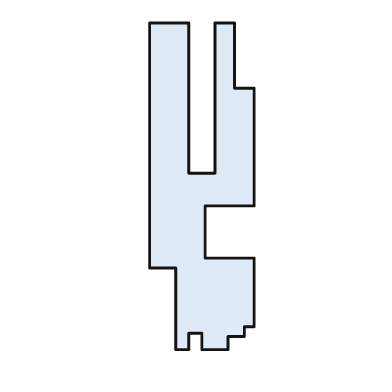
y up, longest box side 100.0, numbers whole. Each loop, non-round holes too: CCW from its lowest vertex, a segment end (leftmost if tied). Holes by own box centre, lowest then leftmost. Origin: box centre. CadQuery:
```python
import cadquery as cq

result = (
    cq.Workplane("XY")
    .moveTo(-8.0, -50.0)
    .lineTo(-4.0, -50.0)
    .lineTo(-4.0, -45.0)
    .lineTo(0.0, -45.0)
    .lineTo(0.0, -50.0)
    .lineTo(8.0, -50.0)
    .lineTo(8.0, -46.0)
    .lineTo(13.0, -46.0)
    .lineTo(13.0, -43.0)
    .lineTo(16.0, -43.0)
    .lineTo(16.0, -22.0)
    .lineTo(1.0, -22.0)
    .lineTo(1.0, -6.0)
    .lineTo(16.0, -6.0)
    .lineTo(16.0, 30.0)
    .lineTo(10.0, 30.0)
    .lineTo(10.0, 50.0)
    .lineTo(4.0, 50.0)
    .lineTo(4.0, 4.0)
    .lineTo(-4.0, 4.0)
    .lineTo(-4.0, 50.0)
    .lineTo(-16.0, 50.0)
    .lineTo(-16.0, -25.0)
    .lineTo(-8.0, -25.0)
    .close()
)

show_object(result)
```